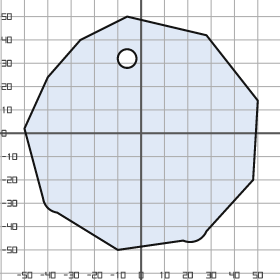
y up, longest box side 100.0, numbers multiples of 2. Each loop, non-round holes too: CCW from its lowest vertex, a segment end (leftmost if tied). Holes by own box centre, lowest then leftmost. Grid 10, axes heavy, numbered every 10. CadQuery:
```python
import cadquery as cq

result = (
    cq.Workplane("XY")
    .moveTo(-10.0, -50.0)
    .lineTo(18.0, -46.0)
    .threePointArc((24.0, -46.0), (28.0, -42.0))
    .lineTo(48.0, -20.0)
    .lineTo(50.0, 14.0)
    .lineTo(28.0, 42.0)
    .lineTo(-6.0, 50.0)
    .lineTo(-26.0, 40.0)
    .lineTo(-40.0, 24.0)
    .lineTo(-50.0, 2.0)
    .lineTo(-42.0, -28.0)
    .threePointArc((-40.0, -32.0), (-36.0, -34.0))
    .close()
    .moveTo(-6.0, 32.0)
    .circle(4.0)
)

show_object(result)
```